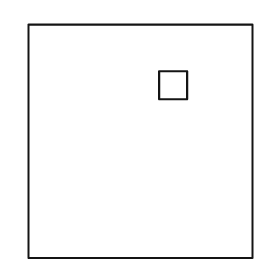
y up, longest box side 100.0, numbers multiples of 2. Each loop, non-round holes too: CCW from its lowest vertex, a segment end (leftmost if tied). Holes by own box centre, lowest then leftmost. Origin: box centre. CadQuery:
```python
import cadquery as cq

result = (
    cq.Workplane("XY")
    .moveTo(-48.0, -50.0)
    .lineTo(48.0, -50.0)
    .lineTo(48.0, 50.0)
    .lineTo(-48.0, 50.0)
    .close()
    .moveTo(8.0, 18.0)
    .lineTo(20.0, 18.0)
    .lineTo(20.0, 30.0)
    .lineTo(8.0, 30.0)
    .close()
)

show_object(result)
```